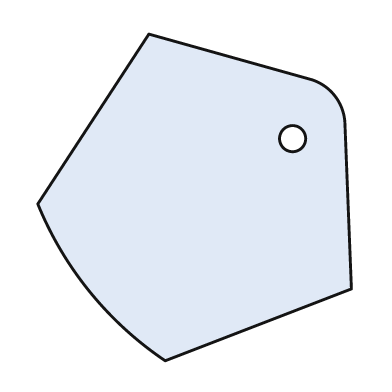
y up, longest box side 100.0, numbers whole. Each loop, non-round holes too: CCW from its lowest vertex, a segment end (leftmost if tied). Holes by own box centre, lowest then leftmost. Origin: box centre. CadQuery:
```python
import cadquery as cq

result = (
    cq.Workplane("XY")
    .moveTo(-9.0, -50.0)
    .lineTo(48.0, -28.0)
    .lineTo(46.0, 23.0)
    .threePointArc((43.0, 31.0), (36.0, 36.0))
    .lineTo(-14.0, 50.0)
    .lineTo(-48.0, -2.0)
    .threePointArc((-32.0, -29.0), (-9.0, -50.0))
    .close()
    .moveTo(30.0, 18.0)
    .circle(4.0)
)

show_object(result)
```